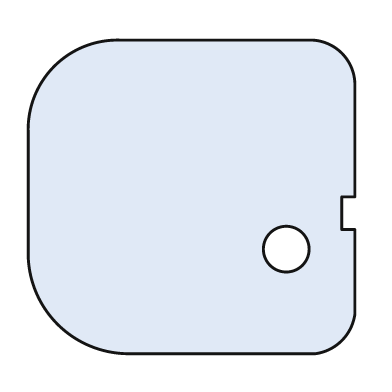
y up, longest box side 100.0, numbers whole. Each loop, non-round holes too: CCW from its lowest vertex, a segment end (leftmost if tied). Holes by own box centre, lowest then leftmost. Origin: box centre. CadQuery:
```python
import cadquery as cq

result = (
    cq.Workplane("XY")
    .moveTo(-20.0, -48.0)
    .lineTo(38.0, -48.0)
    .threePointArc((46.0, -44.0), (50.0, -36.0))
    .lineTo(50.0, -10.0)
    .lineTo(46.0, -10.0)
    .lineTo(46.0, 0.0)
    .lineTo(50.0, 0.0)
    .lineTo(50.0, 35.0)
    .threePointArc((46.0, 44.0), (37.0, 48.0))
    .lineTo(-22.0, 48.0)
    .threePointArc((-42.0, 40.0), (-50.0, 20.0))
    .lineTo(-50.0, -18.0)
    .threePointArc((-41.0, -39.0), (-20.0, -48.0))
    .close()
    .moveTo(29.0, -16.0)
    .circle(7.0)
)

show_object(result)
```